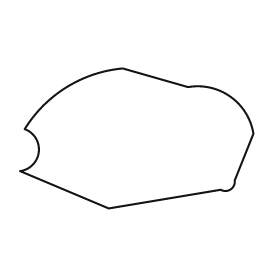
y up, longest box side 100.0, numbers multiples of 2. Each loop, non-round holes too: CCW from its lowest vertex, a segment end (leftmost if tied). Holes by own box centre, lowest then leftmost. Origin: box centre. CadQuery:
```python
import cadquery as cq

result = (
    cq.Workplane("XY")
    .moveTo(-12.0, -30.0)
    .lineTo(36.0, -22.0)
    .threePointArc((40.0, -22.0), (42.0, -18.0))
    .lineTo(50.0, 2.0)
    .threePointArc((40.0, 18.0), (22.0, 22.0))
    .lineTo(-6.0, 30.0)
    .threePointArc((-30.0, 22.0), (-48.0, 4.0))
    .threePointArc((-42.0, -6.0), (-50.0, -14.0))
    .close()
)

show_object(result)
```